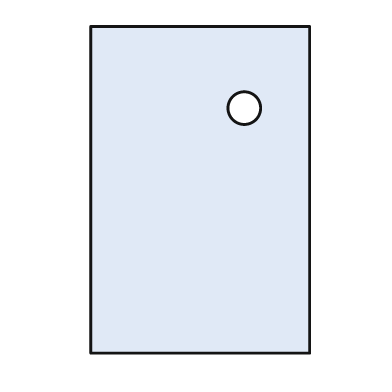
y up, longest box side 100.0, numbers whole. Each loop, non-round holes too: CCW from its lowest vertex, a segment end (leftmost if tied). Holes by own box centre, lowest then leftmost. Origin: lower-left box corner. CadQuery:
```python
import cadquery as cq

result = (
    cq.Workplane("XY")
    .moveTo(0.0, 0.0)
    .lineTo(67.0, 0.0)
    .lineTo(67.0, 100.0)
    .lineTo(0.0, 100.0)
    .close()
    .moveTo(47.0, 75.0)
    .circle(5.0)
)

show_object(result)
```